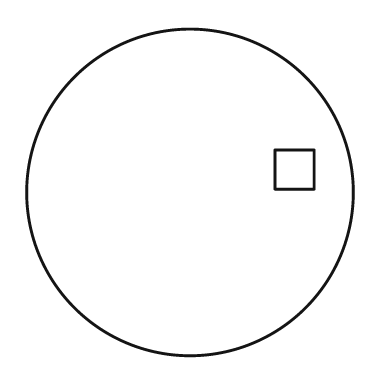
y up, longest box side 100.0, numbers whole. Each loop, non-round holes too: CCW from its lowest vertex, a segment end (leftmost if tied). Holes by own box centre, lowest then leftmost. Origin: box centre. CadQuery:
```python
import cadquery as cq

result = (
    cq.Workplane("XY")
    .moveTo(0.0, 0.0)
    .circle(50.0)
    .moveTo(26.0, 1.0)
    .lineTo(38.0, 1.0)
    .lineTo(38.0, 13.0)
    .lineTo(26.0, 13.0)
    .close()
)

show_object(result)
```